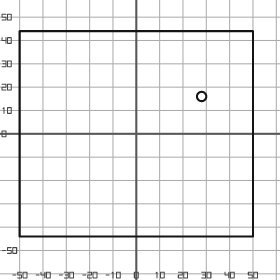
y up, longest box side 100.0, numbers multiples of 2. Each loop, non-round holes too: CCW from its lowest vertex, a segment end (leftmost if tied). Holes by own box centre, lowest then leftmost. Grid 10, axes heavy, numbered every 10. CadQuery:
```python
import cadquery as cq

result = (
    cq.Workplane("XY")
    .moveTo(-50.0, -44.0)
    .lineTo(50.0, -44.0)
    .lineTo(50.0, 44.0)
    .lineTo(-50.0, 44.0)
    .close()
    .moveTo(28.0, 16.0)
    .circle(2.0)
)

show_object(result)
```